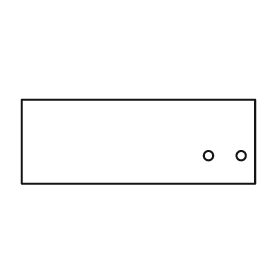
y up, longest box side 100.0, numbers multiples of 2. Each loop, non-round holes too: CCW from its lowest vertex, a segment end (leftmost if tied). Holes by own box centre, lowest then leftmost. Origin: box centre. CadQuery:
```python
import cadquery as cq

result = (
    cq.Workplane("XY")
    .moveTo(-50.0, -18.0)
    .lineTo(50.0, -18.0)
    .lineTo(50.0, 18.0)
    .lineTo(-50.0, 18.0)
    .close()
    .moveTo(30.0, -6.0)
    .circle(2.0)
    .moveTo(44.0, -6.0)
    .circle(2.0)
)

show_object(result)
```